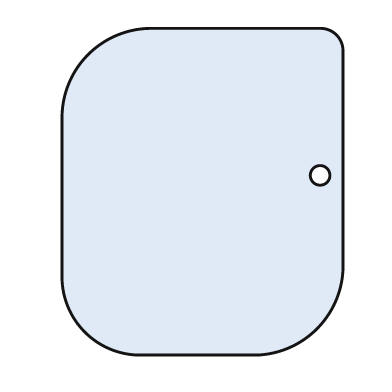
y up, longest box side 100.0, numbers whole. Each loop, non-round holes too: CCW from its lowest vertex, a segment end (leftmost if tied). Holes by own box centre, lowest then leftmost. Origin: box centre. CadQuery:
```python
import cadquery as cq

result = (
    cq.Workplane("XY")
    .moveTo(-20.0, -50.0)
    .lineTo(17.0, -50.0)
    .threePointArc((35.0, -42.0), (43.0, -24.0))
    .lineTo(43.0, 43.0)
    .threePointArc((41.0, 48.0), (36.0, 50.0))
    .lineTo(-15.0, 50.0)
    .threePointArc((-35.0, 42.0), (-43.0, 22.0))
    .lineTo(-43.0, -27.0)
    .threePointArc((-36.0, -43.0), (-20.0, -50.0))
    .close()
    .moveTo(36.0, 5.0)
    .circle(3.0)
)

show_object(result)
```